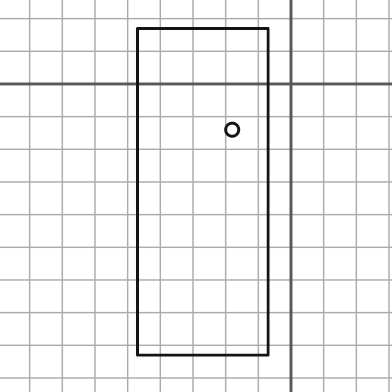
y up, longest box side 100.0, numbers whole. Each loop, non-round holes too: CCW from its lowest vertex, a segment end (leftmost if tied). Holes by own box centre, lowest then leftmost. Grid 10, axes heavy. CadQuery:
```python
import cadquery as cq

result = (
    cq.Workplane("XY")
    .moveTo(-47.0, -83.0)
    .lineTo(-7.0, -83.0)
    .lineTo(-7.0, 17.0)
    .lineTo(-47.0, 17.0)
    .close()
    .moveTo(-18.0, -14.0)
    .circle(2.0)
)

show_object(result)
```